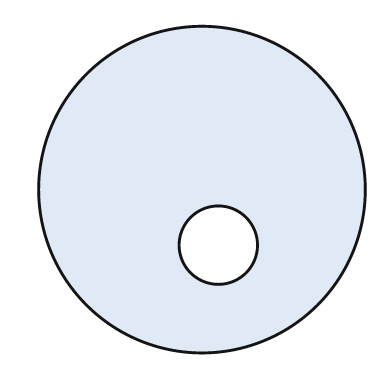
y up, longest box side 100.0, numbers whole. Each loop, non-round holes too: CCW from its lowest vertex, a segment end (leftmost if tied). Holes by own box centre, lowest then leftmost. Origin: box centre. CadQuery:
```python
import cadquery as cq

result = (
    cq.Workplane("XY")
    .moveTo(0.0, 0.0)
    .circle(50.0)
    .moveTo(5.0, -17.0)
    .circle(12.0)
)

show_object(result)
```